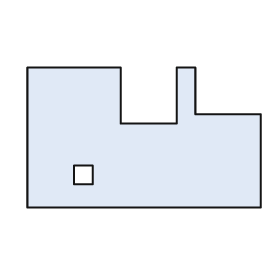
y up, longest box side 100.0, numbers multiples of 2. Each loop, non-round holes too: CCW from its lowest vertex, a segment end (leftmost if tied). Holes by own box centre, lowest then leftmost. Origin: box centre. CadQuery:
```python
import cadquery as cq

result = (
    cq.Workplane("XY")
    .moveTo(-50.0, -30.0)
    .lineTo(50.0, -30.0)
    .lineTo(50.0, 10.0)
    .lineTo(22.0, 10.0)
    .lineTo(22.0, 30.0)
    .lineTo(14.0, 30.0)
    .lineTo(14.0, 6.0)
    .lineTo(-10.0, 6.0)
    .lineTo(-10.0, 30.0)
    .lineTo(-50.0, 30.0)
    .close()
    .moveTo(-30.0, -20.0)
    .lineTo(-22.0, -20.0)
    .lineTo(-22.0, -12.0)
    .lineTo(-30.0, -12.0)
    .close()
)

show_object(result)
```